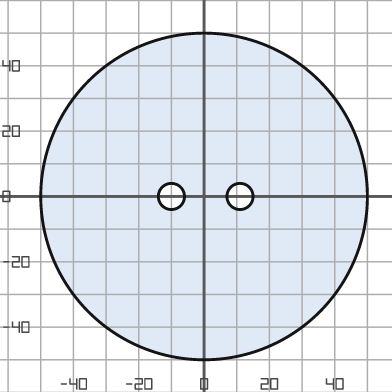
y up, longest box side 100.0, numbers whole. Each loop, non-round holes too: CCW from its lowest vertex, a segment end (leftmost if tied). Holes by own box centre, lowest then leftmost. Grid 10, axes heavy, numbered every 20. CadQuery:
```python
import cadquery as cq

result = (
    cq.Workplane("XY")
    .moveTo(0.0, 0.0)
    .circle(50.0)
    .moveTo(-10.0, 0.0)
    .circle(4.0)
    .moveTo(11.0, 0.0)
    .circle(4.0)
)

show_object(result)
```